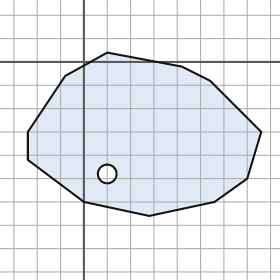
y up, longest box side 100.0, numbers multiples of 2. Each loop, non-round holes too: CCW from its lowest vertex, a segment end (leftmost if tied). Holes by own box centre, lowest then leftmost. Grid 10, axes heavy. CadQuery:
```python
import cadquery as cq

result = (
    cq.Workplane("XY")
    .moveTo(28.0, -66.0)
    .lineTo(56.0, -60.0)
    .lineTo(70.0, -50.0)
    .lineTo(76.0, -30.0)
    .lineTo(54.0, -8.0)
    .lineTo(42.0, -2.0)
    .lineTo(10.0, 4.0)
    .lineTo(-8.0, -6.0)
    .lineTo(-24.0, -30.0)
    .lineTo(-24.0, -42.0)
    .lineTo(0.0, -60.0)
    .close()
    .moveTo(10.0, -48.0)
    .circle(4.0)
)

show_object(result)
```